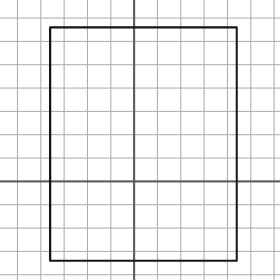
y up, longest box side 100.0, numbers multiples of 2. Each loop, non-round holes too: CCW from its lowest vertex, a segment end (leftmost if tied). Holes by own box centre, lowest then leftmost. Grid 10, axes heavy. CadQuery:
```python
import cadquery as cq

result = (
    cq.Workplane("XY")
    .moveTo(-36.0, -34.0)
    .lineTo(44.0, -34.0)
    .lineTo(44.0, 66.0)
    .lineTo(-36.0, 66.0)
    .close()
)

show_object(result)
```